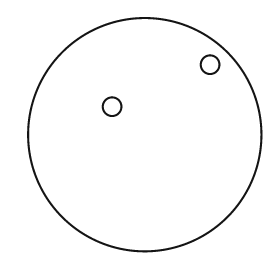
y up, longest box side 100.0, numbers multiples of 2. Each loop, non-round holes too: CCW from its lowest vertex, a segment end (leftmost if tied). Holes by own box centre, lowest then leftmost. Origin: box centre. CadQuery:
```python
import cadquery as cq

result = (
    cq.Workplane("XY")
    .moveTo(0.0, 0.0)
    .circle(50.0)
    .moveTo(-14.0, 12.0)
    .circle(4.0)
    .moveTo(28.0, 30.0)
    .circle(4.0)
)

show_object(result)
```